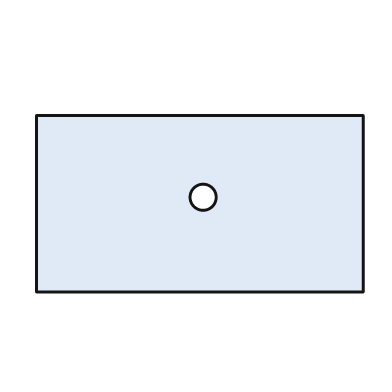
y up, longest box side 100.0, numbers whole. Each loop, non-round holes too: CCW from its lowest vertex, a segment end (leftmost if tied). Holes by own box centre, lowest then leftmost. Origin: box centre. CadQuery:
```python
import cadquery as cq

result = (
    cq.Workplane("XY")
    .moveTo(-50.0, -27.0)
    .lineTo(50.0, -27.0)
    .lineTo(50.0, 27.0)
    .lineTo(-50.0, 27.0)
    .close()
    .moveTo(1.0, 2.0)
    .circle(4.0)
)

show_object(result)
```